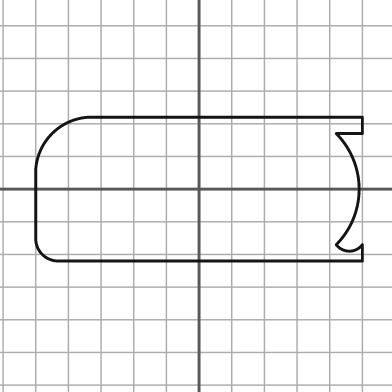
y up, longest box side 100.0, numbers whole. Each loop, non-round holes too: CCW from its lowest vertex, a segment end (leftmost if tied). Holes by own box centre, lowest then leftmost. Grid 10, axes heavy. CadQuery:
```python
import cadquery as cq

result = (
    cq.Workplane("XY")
    .moveTo(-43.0, -22.0)
    .lineTo(50.0, -22.0)
    .lineTo(50.0, -17.0)
    .threePointArc((46.0, -19.0), (42.0, -17.0))
    .threePointArc((49.0, 0.0), (42.0, 17.0))
    .lineTo(50.0, 17.0)
    .lineTo(50.0, 22.0)
    .lineTo(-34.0, 22.0)
    .threePointArc((-45.0, 17.0), (-50.0, 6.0))
    .lineTo(-50.0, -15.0)
    .threePointArc((-48.0, -20.0), (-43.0, -22.0))
    .close()
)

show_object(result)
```